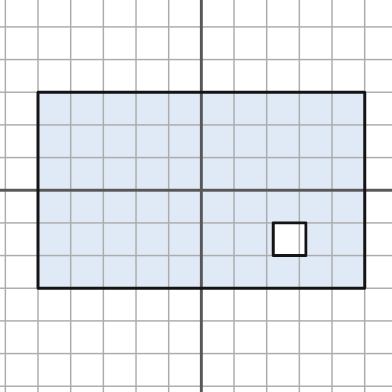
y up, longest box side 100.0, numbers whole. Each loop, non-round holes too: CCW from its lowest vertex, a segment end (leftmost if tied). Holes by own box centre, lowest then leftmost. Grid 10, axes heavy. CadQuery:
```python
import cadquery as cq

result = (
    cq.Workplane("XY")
    .moveTo(-50.0, -30.0)
    .lineTo(50.0, -30.0)
    .lineTo(50.0, 30.0)
    .lineTo(-50.0, 30.0)
    .close()
    .moveTo(22.0, -20.0)
    .lineTo(32.0, -20.0)
    .lineTo(32.0, -10.0)
    .lineTo(22.0, -10.0)
    .close()
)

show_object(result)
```